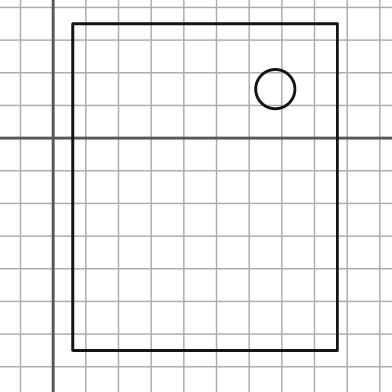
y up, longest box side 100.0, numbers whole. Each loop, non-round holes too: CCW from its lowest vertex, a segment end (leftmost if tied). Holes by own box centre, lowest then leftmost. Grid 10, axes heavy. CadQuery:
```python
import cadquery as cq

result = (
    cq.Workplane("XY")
    .moveTo(6.0, -65.0)
    .lineTo(87.0, -65.0)
    .lineTo(87.0, 35.0)
    .lineTo(6.0, 35.0)
    .close()
    .moveTo(68.0, 15.0)
    .circle(6.0)
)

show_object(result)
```